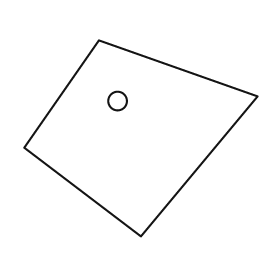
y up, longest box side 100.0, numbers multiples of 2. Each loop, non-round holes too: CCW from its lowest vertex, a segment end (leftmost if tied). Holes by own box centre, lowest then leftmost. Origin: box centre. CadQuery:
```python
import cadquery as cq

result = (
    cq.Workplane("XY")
    .moveTo(0.0, -42.0)
    .lineTo(50.0, 18.0)
    .lineTo(-18.0, 42.0)
    .lineTo(-50.0, -4.0)
    .close()
    .moveTo(-10.0, 16.0)
    .circle(4.0)
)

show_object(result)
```